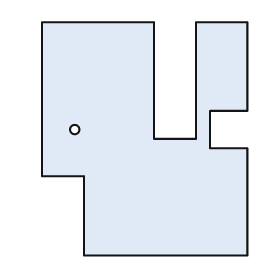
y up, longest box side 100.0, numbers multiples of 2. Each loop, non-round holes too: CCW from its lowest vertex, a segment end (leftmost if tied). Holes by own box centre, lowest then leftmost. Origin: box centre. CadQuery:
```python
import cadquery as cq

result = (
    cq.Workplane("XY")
    .moveTo(-26.0, -50.0)
    .lineTo(44.0, -50.0)
    .lineTo(44.0, -4.0)
    .lineTo(28.0, -4.0)
    .lineTo(28.0, 12.0)
    .lineTo(44.0, 12.0)
    .lineTo(44.0, 50.0)
    .lineTo(22.0, 50.0)
    .lineTo(22.0, 0.0)
    .lineTo(4.0, 0.0)
    .lineTo(4.0, 50.0)
    .lineTo(-44.0, 50.0)
    .lineTo(-44.0, -16.0)
    .lineTo(-26.0, -16.0)
    .close()
    .moveTo(-30.0, 4.0)
    .circle(2.0)
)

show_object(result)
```